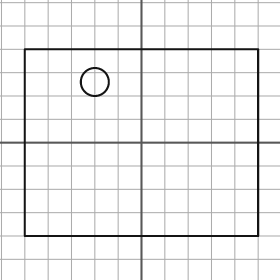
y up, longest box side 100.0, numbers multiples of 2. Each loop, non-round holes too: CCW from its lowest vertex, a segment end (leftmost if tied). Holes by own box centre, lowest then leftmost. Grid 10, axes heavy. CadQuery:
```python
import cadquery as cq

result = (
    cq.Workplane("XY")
    .moveTo(-50.0, -40.0)
    .lineTo(50.0, -40.0)
    .lineTo(50.0, 40.0)
    .lineTo(-50.0, 40.0)
    .close()
    .moveTo(-20.0, 26.0)
    .circle(6.0)
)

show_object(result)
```